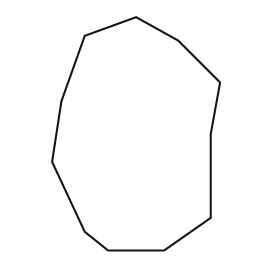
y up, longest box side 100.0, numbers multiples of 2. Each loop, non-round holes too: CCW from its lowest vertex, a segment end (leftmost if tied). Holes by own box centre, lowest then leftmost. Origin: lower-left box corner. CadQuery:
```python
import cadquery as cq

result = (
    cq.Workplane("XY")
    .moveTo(24.0, 0.0)
    .lineTo(48.0, 0.0)
    .lineTo(68.0, 14.0)
    .lineTo(68.0, 50.0)
    .lineTo(72.0, 72.0)
    .lineTo(54.0, 90.0)
    .lineTo(36.0, 100.0)
    .lineTo(14.0, 92.0)
    .lineTo(4.0, 64.0)
    .lineTo(0.0, 38.0)
    .lineTo(14.0, 8.0)
    .close()
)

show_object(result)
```